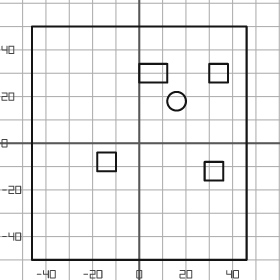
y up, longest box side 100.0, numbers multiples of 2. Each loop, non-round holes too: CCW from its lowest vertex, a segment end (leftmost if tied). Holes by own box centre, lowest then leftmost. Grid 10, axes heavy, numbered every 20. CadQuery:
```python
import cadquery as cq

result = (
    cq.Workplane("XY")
    .moveTo(-46.0, -50.0)
    .lineTo(46.0, -50.0)
    .lineTo(46.0, 50.0)
    .lineTo(-46.0, 50.0)
    .close()
    .moveTo(28.0, -16.0)
    .lineTo(36.0, -16.0)
    .lineTo(36.0, -8.0)
    .lineTo(28.0, -8.0)
    .close()
    .moveTo(-18.0, -12.0)
    .lineTo(-10.0, -12.0)
    .lineTo(-10.0, -4.0)
    .lineTo(-18.0, -4.0)
    .close()
    .moveTo(16.0, 18.0)
    .circle(4.0)
    .moveTo(0.0, 26.0)
    .lineTo(12.0, 26.0)
    .lineTo(12.0, 34.0)
    .lineTo(0.0, 34.0)
    .close()
    .moveTo(30.0, 26.0)
    .lineTo(38.0, 26.0)
    .lineTo(38.0, 34.0)
    .lineTo(30.0, 34.0)
    .close()
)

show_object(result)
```